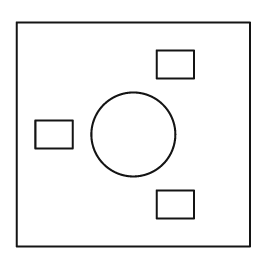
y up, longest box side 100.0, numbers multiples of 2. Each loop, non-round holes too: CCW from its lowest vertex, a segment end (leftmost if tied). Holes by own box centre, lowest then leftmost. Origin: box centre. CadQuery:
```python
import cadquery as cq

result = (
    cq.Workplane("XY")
    .moveTo(-50.0, -48.0)
    .lineTo(50.0, -48.0)
    .lineTo(50.0, 48.0)
    .lineTo(-50.0, 48.0)
    .close()
    .moveTo(10.0, -36.0)
    .lineTo(26.0, -36.0)
    .lineTo(26.0, -24.0)
    .lineTo(10.0, -24.0)
    .close()
    .moveTo(-42.0, -6.0)
    .lineTo(-26.0, -6.0)
    .lineTo(-26.0, 6.0)
    .lineTo(-42.0, 6.0)
    .close()
    .moveTo(0.0, 0.0)
    .circle(18.0)
    .moveTo(10.0, 24.0)
    .lineTo(26.0, 24.0)
    .lineTo(26.0, 36.0)
    .lineTo(10.0, 36.0)
    .close()
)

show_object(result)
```